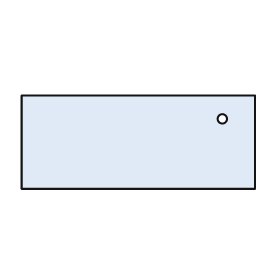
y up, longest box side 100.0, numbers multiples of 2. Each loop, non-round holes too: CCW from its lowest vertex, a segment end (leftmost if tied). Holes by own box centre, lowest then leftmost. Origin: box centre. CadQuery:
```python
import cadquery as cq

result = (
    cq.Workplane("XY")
    .moveTo(-50.0, -20.0)
    .lineTo(50.0, -20.0)
    .lineTo(50.0, 20.0)
    .lineTo(-50.0, 20.0)
    .close()
    .moveTo(36.0, 10.0)
    .circle(2.0)
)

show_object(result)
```